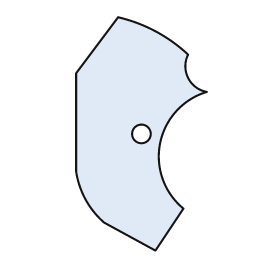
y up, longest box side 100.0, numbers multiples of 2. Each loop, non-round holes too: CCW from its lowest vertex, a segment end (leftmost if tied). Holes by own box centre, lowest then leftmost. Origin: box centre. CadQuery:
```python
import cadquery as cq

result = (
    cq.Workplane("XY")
    .moveTo(6.0, -50.0)
    .lineTo(18.0, -32.0)
    .threePointArc((8.0, -4.0), (28.0, 18.0))
    .threePointArc((20.0, 24.0), (20.0, 34.0))
    .threePointArc((6.0, 44.0), (-10.0, 50.0))
    .lineTo(-28.0, 26.0)
    .lineTo(-28.0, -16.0)
    .threePointArc((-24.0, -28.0), (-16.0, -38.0))
    .close()
    .moveTo(0.0, 0.0)
    .circle(4.0)
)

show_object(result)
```